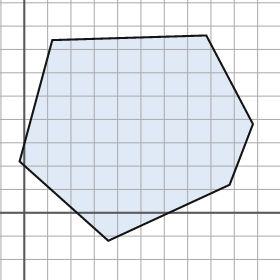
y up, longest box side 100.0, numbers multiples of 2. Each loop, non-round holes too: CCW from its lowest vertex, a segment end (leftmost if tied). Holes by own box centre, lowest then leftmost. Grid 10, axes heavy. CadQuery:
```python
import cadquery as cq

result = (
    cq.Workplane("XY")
    .moveTo(36.0, -12.0)
    .lineTo(88.0, 12.0)
    .lineTo(98.0, 38.0)
    .lineTo(78.0, 76.0)
    .lineTo(12.0, 74.0)
    .lineTo(-2.0, 22.0)
    .close()
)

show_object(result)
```